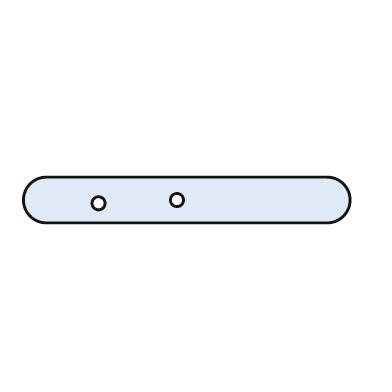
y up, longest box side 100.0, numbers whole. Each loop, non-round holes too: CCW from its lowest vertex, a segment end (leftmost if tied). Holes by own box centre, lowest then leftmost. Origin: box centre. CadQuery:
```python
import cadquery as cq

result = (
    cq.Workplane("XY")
    .moveTo(-43.0, -7.0)
    .lineTo(43.0, -7.0)
    .threePointArc((50.0, 0.0), (43.0, 7.0))
    .lineTo(-43.0, 7.0)
    .threePointArc((-50.0, 0.0), (-43.0, -7.0))
    .close()
    .moveTo(-27.0, -1.0)
    .circle(2.0)
    .moveTo(-3.0, 0.0)
    .circle(2.0)
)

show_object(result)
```